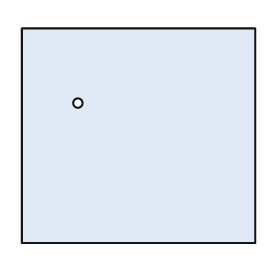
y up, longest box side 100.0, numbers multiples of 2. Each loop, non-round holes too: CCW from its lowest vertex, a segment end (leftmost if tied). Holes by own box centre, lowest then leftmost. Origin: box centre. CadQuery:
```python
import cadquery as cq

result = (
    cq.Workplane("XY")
    .moveTo(-50.0, -46.0)
    .lineTo(50.0, -46.0)
    .lineTo(50.0, 46.0)
    .lineTo(-50.0, 46.0)
    .close()
    .moveTo(-26.0, 14.0)
    .circle(2.0)
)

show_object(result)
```